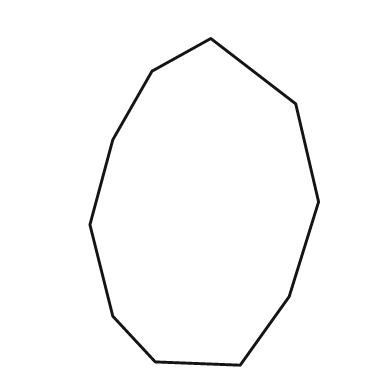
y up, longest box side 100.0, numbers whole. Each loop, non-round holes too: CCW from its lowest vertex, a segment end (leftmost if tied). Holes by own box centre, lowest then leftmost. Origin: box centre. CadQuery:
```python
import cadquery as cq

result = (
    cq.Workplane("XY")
    .moveTo(11.0, -50.0)
    .lineTo(26.0, -29.0)
    .lineTo(35.0, 0.0)
    .lineTo(28.0, 30.0)
    .lineTo(2.0, 50.0)
    .lineTo(-16.0, 40.0)
    .lineTo(-28.0, 19.0)
    .lineTo(-35.0, -7.0)
    .lineTo(-28.0, -35.0)
    .lineTo(-15.0, -49.0)
    .close()
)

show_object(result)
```